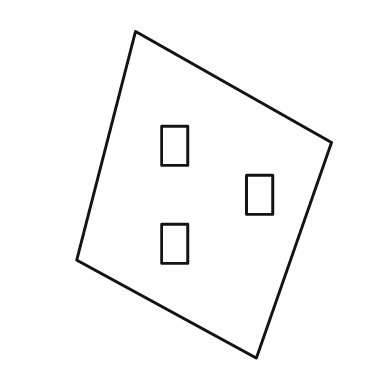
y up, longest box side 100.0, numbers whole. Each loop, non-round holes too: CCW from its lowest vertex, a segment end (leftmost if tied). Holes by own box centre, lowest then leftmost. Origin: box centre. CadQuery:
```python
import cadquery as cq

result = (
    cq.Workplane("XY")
    .moveTo(16.0, -50.0)
    .lineTo(39.0, 16.0)
    .lineTo(-21.0, 50.0)
    .lineTo(-39.0, -20.0)
    .close()
    .moveTo(-13.0, -21.0)
    .lineTo(-5.0, -21.0)
    .lineTo(-5.0, -9.0)
    .lineTo(-13.0, -9.0)
    .close()
    .moveTo(13.0, -6.0)
    .lineTo(21.0, -6.0)
    .lineTo(21.0, 6.0)
    .lineTo(13.0, 6.0)
    .close()
    .moveTo(-13.0, 9.0)
    .lineTo(-5.0, 9.0)
    .lineTo(-5.0, 21.0)
    .lineTo(-13.0, 21.0)
    .close()
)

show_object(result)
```